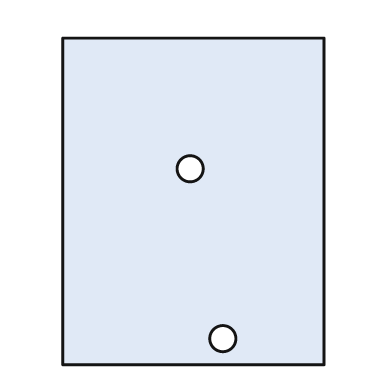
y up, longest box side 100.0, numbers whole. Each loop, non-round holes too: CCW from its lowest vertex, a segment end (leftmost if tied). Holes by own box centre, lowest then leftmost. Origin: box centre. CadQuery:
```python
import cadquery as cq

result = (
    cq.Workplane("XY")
    .moveTo(-40.0, -50.0)
    .lineTo(40.0, -50.0)
    .lineTo(40.0, 50.0)
    .lineTo(-40.0, 50.0)
    .close()
    .moveTo(9.0, -42.0)
    .circle(4.0)
    .moveTo(-1.0, 10.0)
    .circle(4.0)
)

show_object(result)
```